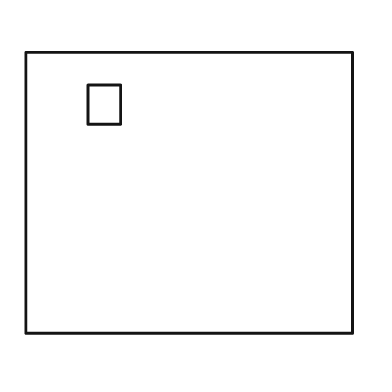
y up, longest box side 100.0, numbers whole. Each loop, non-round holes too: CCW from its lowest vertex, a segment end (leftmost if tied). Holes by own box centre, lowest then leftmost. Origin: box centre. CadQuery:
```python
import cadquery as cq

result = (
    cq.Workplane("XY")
    .moveTo(-50.0, -43.0)
    .lineTo(50.0, -43.0)
    .lineTo(50.0, 43.0)
    .lineTo(-50.0, 43.0)
    .close()
    .moveTo(-31.0, 21.0)
    .lineTo(-21.0, 21.0)
    .lineTo(-21.0, 33.0)
    .lineTo(-31.0, 33.0)
    .close()
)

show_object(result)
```